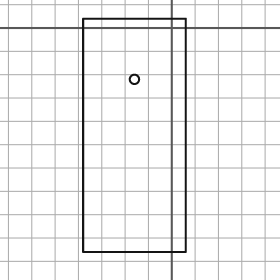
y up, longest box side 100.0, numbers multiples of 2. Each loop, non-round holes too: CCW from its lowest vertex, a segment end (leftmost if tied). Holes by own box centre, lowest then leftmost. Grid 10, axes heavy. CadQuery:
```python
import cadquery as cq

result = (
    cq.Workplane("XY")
    .moveTo(-38.0, -96.0)
    .lineTo(6.0, -96.0)
    .lineTo(6.0, 4.0)
    .lineTo(-38.0, 4.0)
    .close()
    .moveTo(-16.0, -22.0)
    .circle(2.0)
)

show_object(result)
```